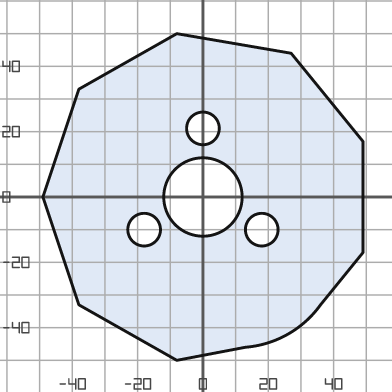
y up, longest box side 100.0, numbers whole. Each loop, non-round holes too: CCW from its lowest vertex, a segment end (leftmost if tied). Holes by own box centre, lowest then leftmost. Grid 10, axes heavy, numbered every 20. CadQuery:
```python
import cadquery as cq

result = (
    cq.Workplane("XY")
    .moveTo(-8.0, -50.0)
    .lineTo(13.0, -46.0)
    .threePointArc((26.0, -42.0), (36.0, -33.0))
    .lineTo(49.0, -17.0)
    .lineTo(49.0, 17.0)
    .lineTo(27.0, 44.0)
    .lineTo(-8.0, 50.0)
    .lineTo(-38.0, 33.0)
    .lineTo(-49.0, 0.0)
    .lineTo(-38.0, -33.0)
    .close()
    .moveTo(-18.0, -10.0)
    .circle(5.0)
    .moveTo(18.0, -10.0)
    .circle(5.0)
    .moveTo(0.0, 0.0)
    .circle(12.0)
    .moveTo(0.0, 21.0)
    .circle(5.0)
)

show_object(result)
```